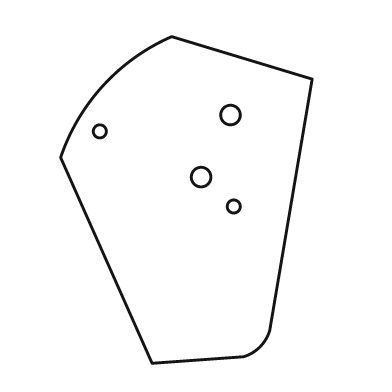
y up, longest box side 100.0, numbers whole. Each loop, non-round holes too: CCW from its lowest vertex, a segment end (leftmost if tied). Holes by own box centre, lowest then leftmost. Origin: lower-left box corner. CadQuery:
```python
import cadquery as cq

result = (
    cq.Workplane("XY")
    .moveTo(28.0, 0.0)
    .lineTo(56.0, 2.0)
    .threePointArc((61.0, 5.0), (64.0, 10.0))
    .lineTo(77.0, 87.0)
    .lineTo(34.0, 100.0)
    .threePointArc((13.0, 85.0), (0.0, 63.0))
    .close()
    .moveTo(53.0, 48.0)
    .circle(2.0)
    .moveTo(43.0, 57.0)
    .circle(3.0)
    .moveTo(12.0, 71.0)
    .circle(2.0)
    .moveTo(52.0, 76.0)
    .circle(3.0)
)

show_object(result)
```